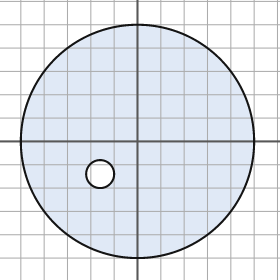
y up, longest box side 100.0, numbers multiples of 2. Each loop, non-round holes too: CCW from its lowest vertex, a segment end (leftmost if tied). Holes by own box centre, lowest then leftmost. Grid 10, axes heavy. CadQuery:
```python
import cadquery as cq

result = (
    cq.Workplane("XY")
    .moveTo(0.0, 0.0)
    .circle(50.0)
    .moveTo(-16.0, -14.0)
    .circle(6.0)
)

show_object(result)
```